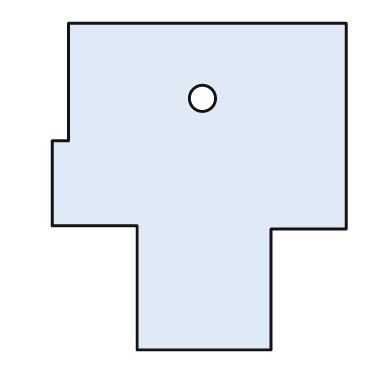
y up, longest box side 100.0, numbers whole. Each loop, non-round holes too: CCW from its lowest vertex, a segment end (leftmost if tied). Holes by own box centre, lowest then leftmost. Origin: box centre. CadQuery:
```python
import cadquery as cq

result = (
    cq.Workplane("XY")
    .moveTo(-19.0, -50.0)
    .lineTo(22.0, -50.0)
    .lineTo(22.0, -13.0)
    .lineTo(45.0, -13.0)
    .lineTo(45.0, 50.0)
    .lineTo(-40.0, 50.0)
    .lineTo(-40.0, 14.0)
    .lineTo(-45.0, 14.0)
    .lineTo(-45.0, -12.0)
    .lineTo(-19.0, -12.0)
    .close()
    .moveTo(1.0, 27.0)
    .circle(4.0)
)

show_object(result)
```